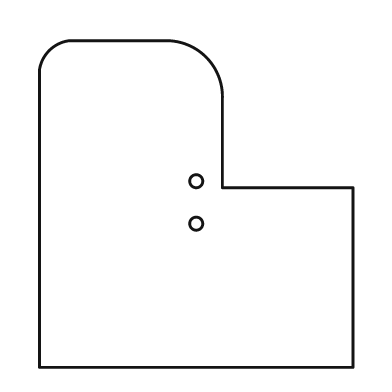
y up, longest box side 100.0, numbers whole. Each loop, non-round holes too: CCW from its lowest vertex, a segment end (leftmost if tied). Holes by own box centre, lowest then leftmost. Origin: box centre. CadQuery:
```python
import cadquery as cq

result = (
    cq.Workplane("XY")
    .moveTo(-48.0, -50.0)
    .lineTo(48.0, -50.0)
    .lineTo(48.0, 5.0)
    .lineTo(8.0, 5.0)
    .lineTo(8.0, 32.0)
    .threePointArc((3.0, 45.0), (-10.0, 50.0))
    .lineTo(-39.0, 50.0)
    .threePointArc((-45.0, 47.0), (-48.0, 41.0))
    .close()
    .moveTo(0.0, -6.0)
    .circle(2.0)
    .moveTo(0.0, 7.0)
    .circle(2.0)
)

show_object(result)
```